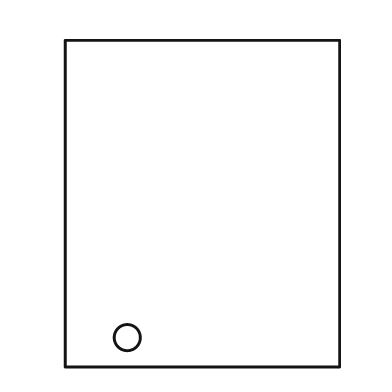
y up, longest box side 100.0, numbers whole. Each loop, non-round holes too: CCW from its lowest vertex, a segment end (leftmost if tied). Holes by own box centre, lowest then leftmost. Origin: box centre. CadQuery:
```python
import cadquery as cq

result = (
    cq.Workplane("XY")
    .moveTo(-42.0, -50.0)
    .lineTo(42.0, -50.0)
    .lineTo(42.0, 50.0)
    .lineTo(-42.0, 50.0)
    .close()
    .moveTo(-23.0, -41.0)
    .circle(4.0)
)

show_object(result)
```